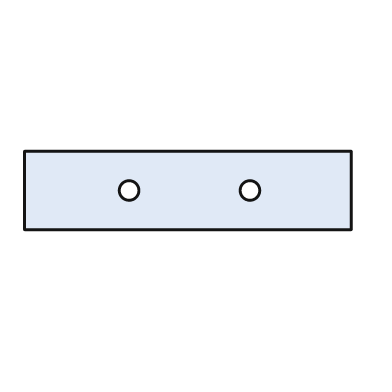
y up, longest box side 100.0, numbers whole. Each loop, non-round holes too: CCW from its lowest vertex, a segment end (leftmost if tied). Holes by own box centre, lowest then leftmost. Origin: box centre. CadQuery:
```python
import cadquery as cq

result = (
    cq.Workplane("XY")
    .moveTo(-50.0, -12.0)
    .lineTo(50.0, -12.0)
    .lineTo(50.0, 12.0)
    .lineTo(-50.0, 12.0)
    .close()
    .moveTo(-18.0, 0.0)
    .circle(3.0)
    .moveTo(19.0, 0.0)
    .circle(3.0)
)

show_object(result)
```